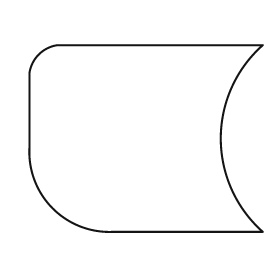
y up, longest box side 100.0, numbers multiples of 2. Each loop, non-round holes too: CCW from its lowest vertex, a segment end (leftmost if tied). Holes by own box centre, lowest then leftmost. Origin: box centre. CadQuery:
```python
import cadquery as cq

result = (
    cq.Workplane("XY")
    .moveTo(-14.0, -40.0)
    .lineTo(50.0, -40.0)
    .threePointArc((32.0, 0.0), (50.0, 40.0))
    .lineTo(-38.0, 40.0)
    .threePointArc((-46.0, 36.0), (-50.0, 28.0))
    .lineTo(-50.0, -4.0)
    .threePointArc((-40.0, -30.0), (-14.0, -40.0))
    .close()
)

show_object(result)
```